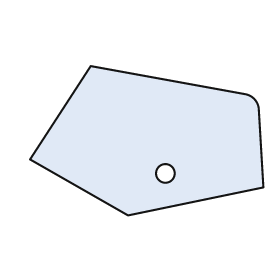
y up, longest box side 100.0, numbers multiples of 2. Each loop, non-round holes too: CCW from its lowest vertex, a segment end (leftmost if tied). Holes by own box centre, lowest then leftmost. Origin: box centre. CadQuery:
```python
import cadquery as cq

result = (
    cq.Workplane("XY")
    .moveTo(-8.0, -32.0)
    .lineTo(50.0, -20.0)
    .lineTo(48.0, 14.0)
    .threePointArc((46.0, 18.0), (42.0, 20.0))
    .lineTo(-24.0, 32.0)
    .lineTo(-50.0, -8.0)
    .close()
    .moveTo(8.0, -14.0)
    .circle(4.0)
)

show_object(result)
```